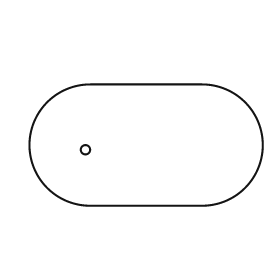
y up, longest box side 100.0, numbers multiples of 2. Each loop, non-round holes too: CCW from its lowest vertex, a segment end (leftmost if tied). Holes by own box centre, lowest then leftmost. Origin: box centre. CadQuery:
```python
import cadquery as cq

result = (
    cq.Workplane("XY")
    .moveTo(-24.0, -26.0)
    .lineTo(24.0, -26.0)
    .threePointArc((50.0, 0.0), (24.0, 26.0))
    .lineTo(-24.0, 26.0)
    .threePointArc((-50.0, 0.0), (-24.0, -26.0))
    .close()
    .moveTo(-26.0, -2.0)
    .circle(2.0)
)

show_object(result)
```